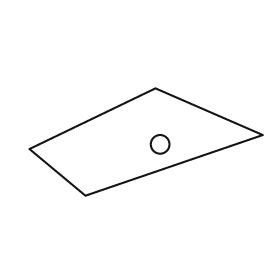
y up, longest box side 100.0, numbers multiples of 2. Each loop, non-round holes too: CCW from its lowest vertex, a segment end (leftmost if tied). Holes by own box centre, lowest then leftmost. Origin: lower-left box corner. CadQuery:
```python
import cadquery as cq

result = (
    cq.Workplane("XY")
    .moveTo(24.0, 0.0)
    .lineTo(100.0, 26.0)
    .lineTo(54.0, 46.0)
    .lineTo(0.0, 20.0)
    .close()
    .moveTo(56.0, 22.0)
    .circle(4.0)
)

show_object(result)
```